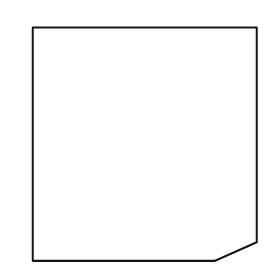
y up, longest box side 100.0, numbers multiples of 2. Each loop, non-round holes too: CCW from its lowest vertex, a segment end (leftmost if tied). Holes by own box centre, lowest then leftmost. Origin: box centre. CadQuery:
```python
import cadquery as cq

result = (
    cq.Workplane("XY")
    .moveTo(-48.0, -50.0)
    .lineTo(30.0, -50.0)
    .lineTo(48.0, -42.0)
    .lineTo(48.0, 50.0)
    .lineTo(-48.0, 50.0)
    .close()
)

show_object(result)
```